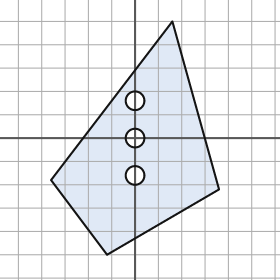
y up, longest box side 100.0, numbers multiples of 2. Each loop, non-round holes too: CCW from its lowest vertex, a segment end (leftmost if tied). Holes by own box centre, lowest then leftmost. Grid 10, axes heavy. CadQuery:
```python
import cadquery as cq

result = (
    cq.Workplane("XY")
    .moveTo(-12.0, -50.0)
    .lineTo(36.0, -22.0)
    .lineTo(16.0, 50.0)
    .lineTo(-36.0, -18.0)
    .close()
    .moveTo(0.0, -16.0)
    .circle(4.0)
    .moveTo(0.0, 0.0)
    .circle(4.0)
    .moveTo(0.0, 16.0)
    .circle(4.0)
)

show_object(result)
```